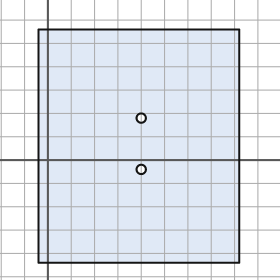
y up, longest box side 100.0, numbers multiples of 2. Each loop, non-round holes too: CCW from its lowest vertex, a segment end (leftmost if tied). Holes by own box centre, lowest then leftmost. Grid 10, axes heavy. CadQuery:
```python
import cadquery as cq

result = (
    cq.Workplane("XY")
    .moveTo(-4.0, -44.0)
    .lineTo(82.0, -44.0)
    .lineTo(82.0, 56.0)
    .lineTo(-4.0, 56.0)
    .close()
    .moveTo(40.0, -4.0)
    .circle(2.0)
    .moveTo(40.0, 18.0)
    .circle(2.0)
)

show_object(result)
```